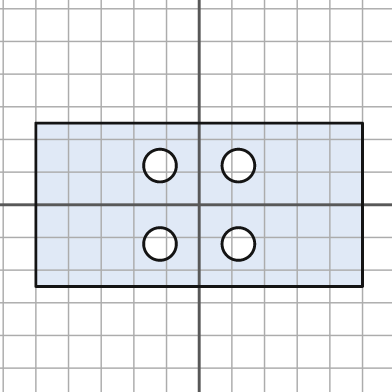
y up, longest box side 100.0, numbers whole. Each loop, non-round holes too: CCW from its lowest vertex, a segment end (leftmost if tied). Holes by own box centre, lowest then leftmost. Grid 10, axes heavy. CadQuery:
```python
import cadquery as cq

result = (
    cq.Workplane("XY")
    .moveTo(-50.0, -25.0)
    .lineTo(50.0, -25.0)
    .lineTo(50.0, 25.0)
    .lineTo(-50.0, 25.0)
    .close()
    .moveTo(-12.0, -12.0)
    .circle(5.0)
    .moveTo(12.0, -12.0)
    .circle(5.0)
    .moveTo(-12.0, 12.0)
    .circle(5.0)
    .moveTo(12.0, 12.0)
    .circle(5.0)
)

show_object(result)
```